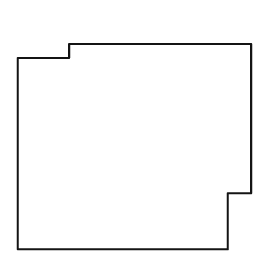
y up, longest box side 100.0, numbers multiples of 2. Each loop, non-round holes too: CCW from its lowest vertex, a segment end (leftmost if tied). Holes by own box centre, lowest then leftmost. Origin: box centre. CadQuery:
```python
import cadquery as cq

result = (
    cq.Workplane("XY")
    .moveTo(-50.0, -44.0)
    .lineTo(40.0, -44.0)
    .lineTo(40.0, -20.0)
    .lineTo(50.0, -20.0)
    .lineTo(50.0, 44.0)
    .lineTo(-28.0, 44.0)
    .lineTo(-28.0, 38.0)
    .lineTo(-50.0, 38.0)
    .close()
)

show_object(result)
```